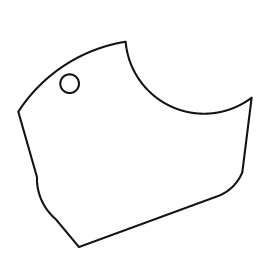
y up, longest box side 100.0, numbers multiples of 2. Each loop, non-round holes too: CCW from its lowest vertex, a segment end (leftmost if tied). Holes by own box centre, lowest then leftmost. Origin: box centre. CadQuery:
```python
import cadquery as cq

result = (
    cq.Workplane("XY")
    .moveTo(-24.0, -44.0)
    .lineTo(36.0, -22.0)
    .threePointArc((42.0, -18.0), (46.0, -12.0))
    .lineTo(50.0, 20.0)
    .threePointArc((16.0, 16.0), (-4.0, 44.0))
    .threePointArc((-30.0, 34.0), (-50.0, 14.0))
    .lineTo(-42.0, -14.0)
    .threePointArc((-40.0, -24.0), (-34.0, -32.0))
    .close()
    .moveTo(-28.0, 26.0)
    .circle(4.0)
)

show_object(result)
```